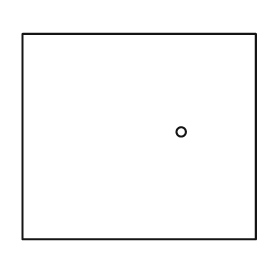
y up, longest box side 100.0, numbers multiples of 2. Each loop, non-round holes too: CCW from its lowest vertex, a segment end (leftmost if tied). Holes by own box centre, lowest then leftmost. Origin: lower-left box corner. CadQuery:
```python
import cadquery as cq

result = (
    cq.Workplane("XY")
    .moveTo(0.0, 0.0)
    .lineTo(100.0, 0.0)
    .lineTo(100.0, 88.0)
    .lineTo(0.0, 88.0)
    .close()
    .moveTo(68.0, 46.0)
    .circle(2.0)
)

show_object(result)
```